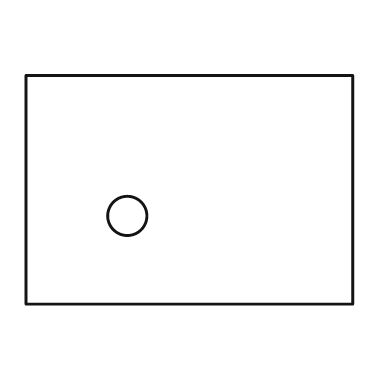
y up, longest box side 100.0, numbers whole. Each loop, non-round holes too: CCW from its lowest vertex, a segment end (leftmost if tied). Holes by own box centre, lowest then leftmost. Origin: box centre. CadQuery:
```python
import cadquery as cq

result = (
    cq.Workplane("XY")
    .moveTo(-50.0, -35.0)
    .lineTo(50.0, -35.0)
    .lineTo(50.0, 35.0)
    .lineTo(-50.0, 35.0)
    .close()
    .moveTo(-19.0, -8.0)
    .circle(6.0)
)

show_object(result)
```